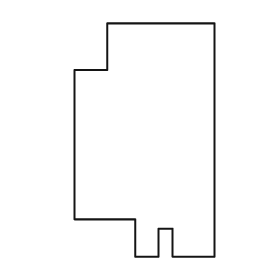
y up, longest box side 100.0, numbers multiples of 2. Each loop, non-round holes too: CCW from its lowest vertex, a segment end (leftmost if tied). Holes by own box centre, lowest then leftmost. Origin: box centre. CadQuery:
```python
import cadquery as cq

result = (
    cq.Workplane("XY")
    .moveTo(-4.0, -50.0)
    .lineTo(6.0, -50.0)
    .lineTo(6.0, -38.0)
    .lineTo(12.0, -38.0)
    .lineTo(12.0, -50.0)
    .lineTo(30.0, -50.0)
    .lineTo(30.0, 50.0)
    .lineTo(-16.0, 50.0)
    .lineTo(-16.0, 30.0)
    .lineTo(-30.0, 30.0)
    .lineTo(-30.0, -34.0)
    .lineTo(-4.0, -34.0)
    .close()
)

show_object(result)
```